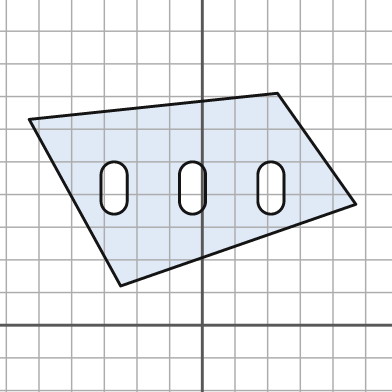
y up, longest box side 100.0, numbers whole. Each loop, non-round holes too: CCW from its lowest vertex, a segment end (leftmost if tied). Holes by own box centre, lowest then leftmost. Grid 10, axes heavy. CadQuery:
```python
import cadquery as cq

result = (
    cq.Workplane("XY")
    .moveTo(-25.0, 12.0)
    .lineTo(47.0, 37.0)
    .lineTo(23.0, 71.0)
    .lineTo(-53.0, 63.0)
    .close()
    .moveTo(-31.0, 38.0)
    .threePointArc((-27.0, 34.0), (-23.0, 38.0))
    .lineTo(-23.0, 46.0)
    .threePointArc((-27.0, 50.0), (-31.0, 46.0))
    .close()
    .moveTo(-7.0, 38.0)
    .threePointArc((-3.0, 34.0), (1.0, 38.0))
    .lineTo(1.0, 46.0)
    .threePointArc((-3.0, 50.0), (-7.0, 46.0))
    .close()
    .moveTo(17.0, 38.0)
    .threePointArc((21.0, 34.0), (25.0, 38.0))
    .lineTo(25.0, 46.0)
    .threePointArc((21.0, 50.0), (17.0, 46.0))
    .close()
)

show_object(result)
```